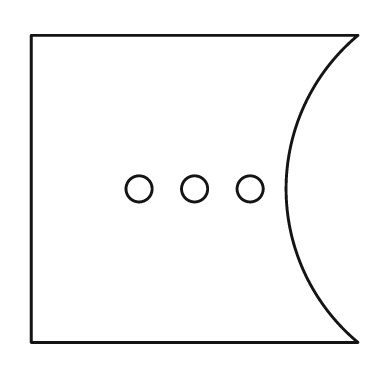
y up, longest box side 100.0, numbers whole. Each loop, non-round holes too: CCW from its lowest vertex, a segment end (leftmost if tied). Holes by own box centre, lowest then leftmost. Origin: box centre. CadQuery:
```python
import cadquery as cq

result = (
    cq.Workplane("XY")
    .moveTo(-50.0, -47.0)
    .lineTo(50.0, -47.0)
    .threePointArc((28.0, 0.0), (50.0, 47.0))
    .lineTo(-50.0, 47.0)
    .close()
    .moveTo(-17.0, 0.0)
    .circle(4.0)
    .moveTo(0.0, 0.0)
    .circle(4.0)
    .moveTo(17.0, 0.0)
    .circle(4.0)
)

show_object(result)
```